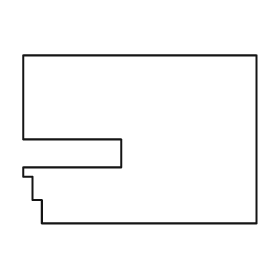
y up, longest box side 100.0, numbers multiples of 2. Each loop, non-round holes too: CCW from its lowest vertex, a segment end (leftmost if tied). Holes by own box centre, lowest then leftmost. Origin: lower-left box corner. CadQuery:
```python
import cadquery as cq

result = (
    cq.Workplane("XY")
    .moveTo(8.0, 0.0)
    .lineTo(100.0, 0.0)
    .lineTo(100.0, 72.0)
    .lineTo(0.0, 72.0)
    .lineTo(0.0, 36.0)
    .lineTo(42.0, 36.0)
    .lineTo(42.0, 24.0)
    .lineTo(0.0, 24.0)
    .lineTo(0.0, 20.0)
    .lineTo(4.0, 20.0)
    .lineTo(4.0, 10.0)
    .lineTo(8.0, 10.0)
    .close()
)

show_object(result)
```